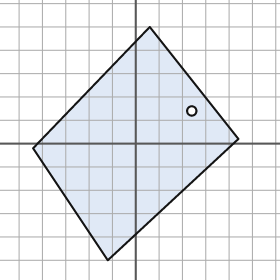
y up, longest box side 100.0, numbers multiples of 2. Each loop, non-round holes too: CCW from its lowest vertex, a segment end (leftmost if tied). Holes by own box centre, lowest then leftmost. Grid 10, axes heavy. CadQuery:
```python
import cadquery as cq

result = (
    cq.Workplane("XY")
    .moveTo(-12.0, -50.0)
    .lineTo(44.0, 2.0)
    .lineTo(6.0, 50.0)
    .lineTo(-44.0, -2.0)
    .close()
    .moveTo(24.0, 14.0)
    .circle(2.0)
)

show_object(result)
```